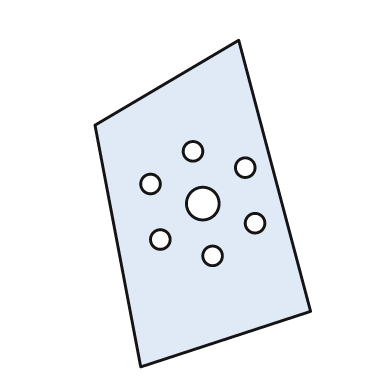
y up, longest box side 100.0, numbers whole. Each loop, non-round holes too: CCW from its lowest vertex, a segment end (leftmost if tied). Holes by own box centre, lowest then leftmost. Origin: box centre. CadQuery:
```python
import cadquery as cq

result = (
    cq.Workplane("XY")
    .moveTo(-19.0, -50.0)
    .lineTo(33.0, -33.0)
    .lineTo(11.0, 50.0)
    .lineTo(-33.0, 24.0)
    .close()
    .moveTo(3.0, -16.0)
    .circle(3.0)
    .moveTo(-13.0, -11.0)
    .circle(3.0)
    .moveTo(16.0, -6.0)
    .circle(3.0)
    .moveTo(0.0, 0.0)
    .circle(5.0)
    .moveTo(-16.0, 6.0)
    .circle(3.0)
    .moveTo(13.0, 11.0)
    .circle(3.0)
    .moveTo(-3.0, 16.0)
    .circle(3.0)
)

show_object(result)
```